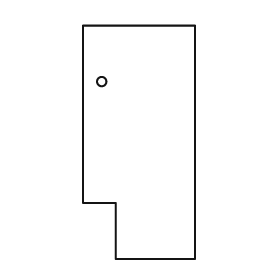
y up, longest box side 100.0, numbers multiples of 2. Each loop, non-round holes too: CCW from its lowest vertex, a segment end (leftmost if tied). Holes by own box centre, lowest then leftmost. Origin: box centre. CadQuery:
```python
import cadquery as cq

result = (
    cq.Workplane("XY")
    .moveTo(-10.0, -50.0)
    .lineTo(24.0, -50.0)
    .lineTo(24.0, 50.0)
    .lineTo(-24.0, 50.0)
    .lineTo(-24.0, -26.0)
    .lineTo(-10.0, -26.0)
    .close()
    .moveTo(-16.0, 26.0)
    .circle(2.0)
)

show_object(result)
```